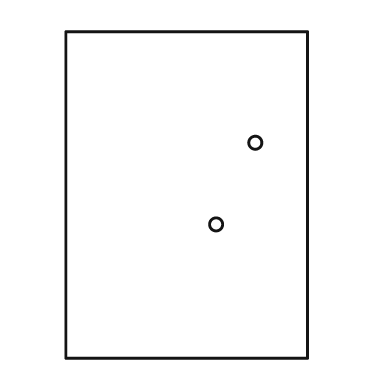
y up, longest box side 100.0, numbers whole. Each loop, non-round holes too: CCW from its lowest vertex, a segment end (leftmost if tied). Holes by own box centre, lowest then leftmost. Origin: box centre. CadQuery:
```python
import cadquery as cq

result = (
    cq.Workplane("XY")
    .moveTo(-37.0, -50.0)
    .lineTo(37.0, -50.0)
    .lineTo(37.0, 50.0)
    .lineTo(-37.0, 50.0)
    .close()
    .moveTo(9.0, -9.0)
    .circle(2.0)
    .moveTo(21.0, 16.0)
    .circle(2.0)
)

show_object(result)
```